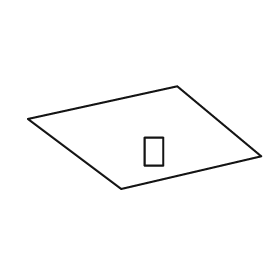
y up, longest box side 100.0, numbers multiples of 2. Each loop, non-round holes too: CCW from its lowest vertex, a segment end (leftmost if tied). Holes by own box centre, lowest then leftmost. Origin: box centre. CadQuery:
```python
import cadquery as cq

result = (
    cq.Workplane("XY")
    .moveTo(-10.0, -22.0)
    .lineTo(50.0, -8.0)
    .lineTo(14.0, 22.0)
    .lineTo(-50.0, 8.0)
    .close()
    .moveTo(0.0, -12.0)
    .lineTo(8.0, -12.0)
    .lineTo(8.0, 0.0)
    .lineTo(0.0, 0.0)
    .close()
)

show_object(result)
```